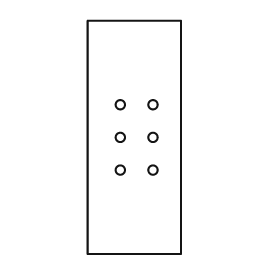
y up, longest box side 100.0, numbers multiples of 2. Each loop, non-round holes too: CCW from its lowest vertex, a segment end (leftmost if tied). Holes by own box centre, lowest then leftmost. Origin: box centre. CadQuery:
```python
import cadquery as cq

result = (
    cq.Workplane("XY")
    .moveTo(-20.0, -50.0)
    .lineTo(20.0, -50.0)
    .lineTo(20.0, 50.0)
    .lineTo(-20.0, 50.0)
    .close()
    .moveTo(-6.0, -14.0)
    .circle(2.0)
    .moveTo(8.0, -14.0)
    .circle(2.0)
    .moveTo(-6.0, 0.0)
    .circle(2.0)
    .moveTo(8.0, 0.0)
    .circle(2.0)
    .moveTo(-6.0, 14.0)
    .circle(2.0)
    .moveTo(8.0, 14.0)
    .circle(2.0)
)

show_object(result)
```